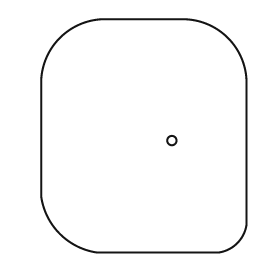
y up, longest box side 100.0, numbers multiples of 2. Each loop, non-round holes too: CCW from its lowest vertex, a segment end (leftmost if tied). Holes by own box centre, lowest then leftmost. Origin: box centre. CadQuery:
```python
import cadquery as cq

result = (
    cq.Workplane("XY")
    .moveTo(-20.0, -50.0)
    .lineTo(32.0, -50.0)
    .threePointArc((40.0, -46.0), (44.0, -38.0))
    .lineTo(44.0, 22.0)
    .threePointArc((36.0, 42.0), (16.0, 50.0))
    .lineTo(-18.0, 50.0)
    .threePointArc((-36.0, 42.0), (-44.0, 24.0))
    .lineTo(-44.0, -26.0)
    .threePointArc((-36.0, -42.0), (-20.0, -50.0))
    .close()
    .moveTo(12.0, -2.0)
    .circle(2.0)
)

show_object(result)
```